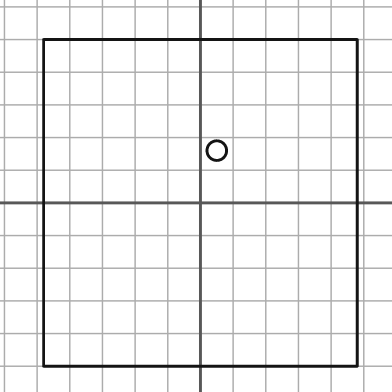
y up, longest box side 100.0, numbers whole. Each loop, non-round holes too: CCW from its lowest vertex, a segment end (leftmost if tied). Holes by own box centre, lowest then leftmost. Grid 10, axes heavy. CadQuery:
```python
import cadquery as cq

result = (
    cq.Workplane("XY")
    .moveTo(-48.0, -50.0)
    .lineTo(48.0, -50.0)
    .lineTo(48.0, 50.0)
    .lineTo(-48.0, 50.0)
    .close()
    .moveTo(5.0, 16.0)
    .circle(3.0)
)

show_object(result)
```